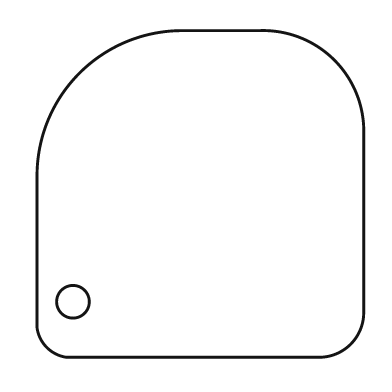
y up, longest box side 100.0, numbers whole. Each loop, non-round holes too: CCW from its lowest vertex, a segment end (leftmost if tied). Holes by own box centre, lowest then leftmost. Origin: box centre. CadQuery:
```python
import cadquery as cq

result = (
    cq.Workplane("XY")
    .moveTo(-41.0, -50.0)
    .lineTo(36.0, -50.0)
    .threePointArc((46.0, -46.0), (50.0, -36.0))
    .lineTo(50.0, 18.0)
    .threePointArc((41.0, 41.0), (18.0, 50.0))
    .lineTo(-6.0, 50.0)
    .threePointArc((-37.0, 37.0), (-50.0, 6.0))
    .lineTo(-50.0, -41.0)
    .threePointArc((-47.0, -47.0), (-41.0, -50.0))
    .close()
    .moveTo(-39.0, -33.0)
    .circle(5.0)
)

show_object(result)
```